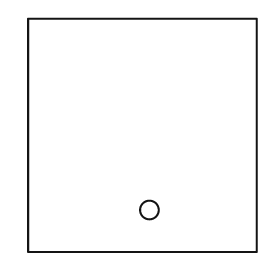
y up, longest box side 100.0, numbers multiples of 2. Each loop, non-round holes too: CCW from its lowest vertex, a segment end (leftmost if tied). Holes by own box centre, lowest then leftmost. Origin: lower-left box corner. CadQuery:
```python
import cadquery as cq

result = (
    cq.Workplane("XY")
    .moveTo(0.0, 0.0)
    .lineTo(98.0, 0.0)
    .lineTo(98.0, 100.0)
    .lineTo(0.0, 100.0)
    .close()
    .moveTo(52.0, 18.0)
    .circle(4.0)
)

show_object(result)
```